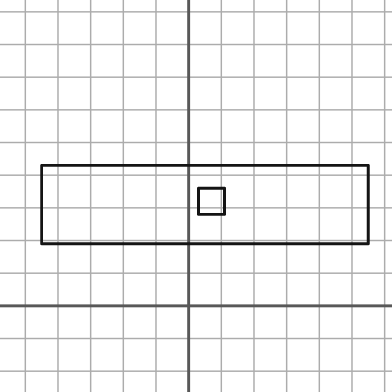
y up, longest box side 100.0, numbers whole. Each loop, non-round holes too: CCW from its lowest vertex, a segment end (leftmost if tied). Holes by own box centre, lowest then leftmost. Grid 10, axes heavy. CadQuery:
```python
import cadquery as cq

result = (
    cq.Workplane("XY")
    .moveTo(-45.0, 19.0)
    .lineTo(55.0, 19.0)
    .lineTo(55.0, 43.0)
    .lineTo(-45.0, 43.0)
    .close()
    .moveTo(3.0, 28.0)
    .lineTo(11.0, 28.0)
    .lineTo(11.0, 36.0)
    .lineTo(3.0, 36.0)
    .close()
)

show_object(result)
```